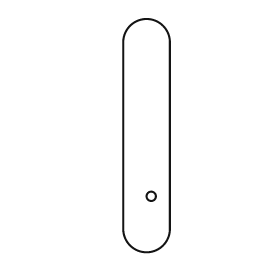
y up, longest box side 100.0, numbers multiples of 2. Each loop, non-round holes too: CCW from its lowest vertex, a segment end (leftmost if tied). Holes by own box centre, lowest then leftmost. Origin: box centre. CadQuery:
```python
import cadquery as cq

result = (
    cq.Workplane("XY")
    .moveTo(-10.0, -40.0)
    .threePointArc((0.0, -50.0), (10.0, -40.0))
    .lineTo(10.0, 40.0)
    .threePointArc((0.0, 50.0), (-10.0, 40.0))
    .close()
    .moveTo(2.0, -26.0)
    .circle(2.0)
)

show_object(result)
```